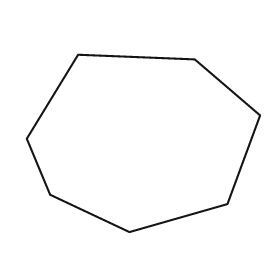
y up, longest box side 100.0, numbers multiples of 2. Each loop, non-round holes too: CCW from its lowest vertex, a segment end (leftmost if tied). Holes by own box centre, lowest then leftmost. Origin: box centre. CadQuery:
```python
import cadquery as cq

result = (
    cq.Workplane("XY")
    .moveTo(-6.0, -38.0)
    .lineTo(36.0, -26.0)
    .lineTo(50.0, 12.0)
    .lineTo(22.0, 36.0)
    .lineTo(-28.0, 38.0)
    .lineTo(-50.0, 2.0)
    .lineTo(-40.0, -22.0)
    .close()
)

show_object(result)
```